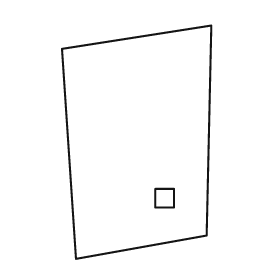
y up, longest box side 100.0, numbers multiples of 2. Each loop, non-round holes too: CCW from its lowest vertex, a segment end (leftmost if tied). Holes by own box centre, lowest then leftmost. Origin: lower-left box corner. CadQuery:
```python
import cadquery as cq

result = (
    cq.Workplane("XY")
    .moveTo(6.0, 0.0)
    .lineTo(62.0, 10.0)
    .lineTo(64.0, 100.0)
    .lineTo(0.0, 90.0)
    .close()
    .moveTo(40.0, 22.0)
    .lineTo(48.0, 22.0)
    .lineTo(48.0, 30.0)
    .lineTo(40.0, 30.0)
    .close()
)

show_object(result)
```